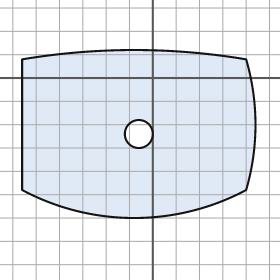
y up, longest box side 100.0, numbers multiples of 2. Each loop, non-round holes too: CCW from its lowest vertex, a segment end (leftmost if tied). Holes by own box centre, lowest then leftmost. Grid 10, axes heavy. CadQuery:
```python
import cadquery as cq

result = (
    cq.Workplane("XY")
    .moveTo(-56.0, -48.0)
    .threePointArc((-8.0, -60.0), (40.0, -48.0))
    .threePointArc((44.0, -20.0), (40.0, 8.0))
    .threePointArc((-8.0, 12.0), (-56.0, 8.0))
    .close()
    .moveTo(-6.0, -24.0)
    .circle(6.0)
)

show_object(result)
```